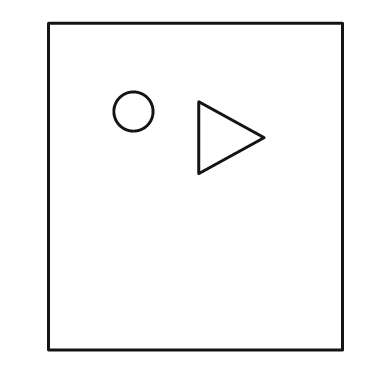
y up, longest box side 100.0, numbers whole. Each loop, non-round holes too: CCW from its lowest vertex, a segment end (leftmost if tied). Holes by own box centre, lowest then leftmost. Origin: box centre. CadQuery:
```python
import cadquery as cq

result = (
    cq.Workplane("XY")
    .moveTo(-45.0, -50.0)
    .lineTo(45.0, -50.0)
    .lineTo(45.0, 50.0)
    .lineTo(-45.0, 50.0)
    .close()
    .moveTo(1.0, 4.0)
    .lineTo(21.0, 15.0)
    .lineTo(1.0, 26.0)
    .close()
    .moveTo(-19.0, 23.0)
    .circle(6.0)
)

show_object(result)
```